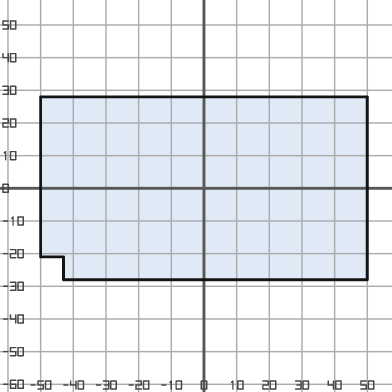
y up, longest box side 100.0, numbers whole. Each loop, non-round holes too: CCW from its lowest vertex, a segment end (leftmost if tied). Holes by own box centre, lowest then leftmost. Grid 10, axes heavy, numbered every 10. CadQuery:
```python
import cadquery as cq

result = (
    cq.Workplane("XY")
    .moveTo(-43.0, -28.0)
    .lineTo(50.0, -28.0)
    .lineTo(50.0, 28.0)
    .lineTo(-50.0, 28.0)
    .lineTo(-50.0, -21.0)
    .lineTo(-43.0, -21.0)
    .close()
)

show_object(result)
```